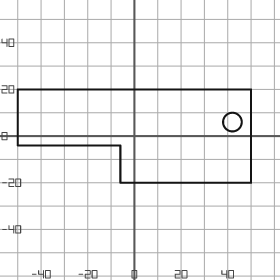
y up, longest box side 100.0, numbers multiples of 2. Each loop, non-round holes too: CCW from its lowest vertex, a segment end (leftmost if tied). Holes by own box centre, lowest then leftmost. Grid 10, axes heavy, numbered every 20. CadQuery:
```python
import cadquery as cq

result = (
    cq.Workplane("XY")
    .moveTo(-6.0, -20.0)
    .lineTo(50.0, -20.0)
    .lineTo(50.0, 20.0)
    .lineTo(-50.0, 20.0)
    .lineTo(-50.0, -4.0)
    .lineTo(-6.0, -4.0)
    .close()
    .moveTo(42.0, 6.0)
    .circle(4.0)
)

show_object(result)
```